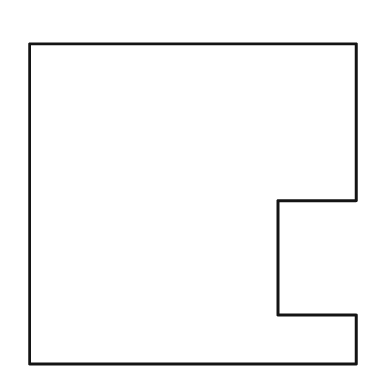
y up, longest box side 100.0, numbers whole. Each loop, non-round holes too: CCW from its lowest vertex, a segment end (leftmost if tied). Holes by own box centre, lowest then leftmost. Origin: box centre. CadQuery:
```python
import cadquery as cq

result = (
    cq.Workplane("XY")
    .moveTo(-50.0, -49.0)
    .lineTo(50.0, -49.0)
    .lineTo(50.0, -34.0)
    .lineTo(26.0, -34.0)
    .lineTo(26.0, 1.0)
    .lineTo(50.0, 1.0)
    .lineTo(50.0, 49.0)
    .lineTo(-50.0, 49.0)
    .close()
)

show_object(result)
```